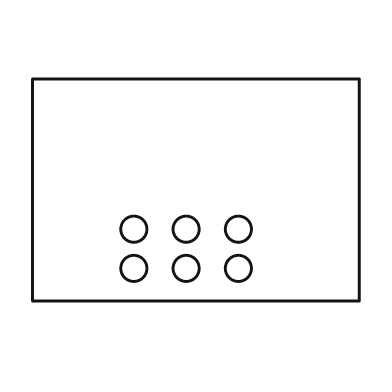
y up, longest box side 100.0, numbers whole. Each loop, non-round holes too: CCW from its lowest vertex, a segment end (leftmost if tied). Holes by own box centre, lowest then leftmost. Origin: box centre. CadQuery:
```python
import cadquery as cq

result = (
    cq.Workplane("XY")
    .moveTo(-50.0, -34.0)
    .lineTo(50.0, -34.0)
    .lineTo(50.0, 34.0)
    .lineTo(-50.0, 34.0)
    .close()
    .moveTo(-19.0, -24.0)
    .circle(4.0)
    .moveTo(-3.0, -24.0)
    .circle(4.0)
    .moveTo(13.0, -24.0)
    .circle(4.0)
    .moveTo(-19.0, -12.0)
    .circle(4.0)
    .moveTo(-3.0, -12.0)
    .circle(4.0)
    .moveTo(13.0, -12.0)
    .circle(4.0)
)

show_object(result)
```